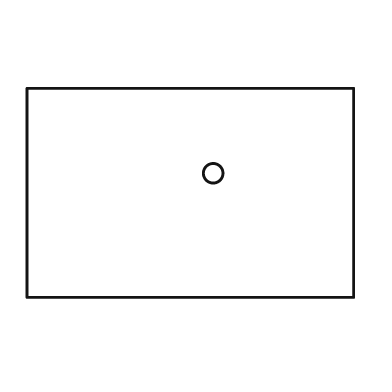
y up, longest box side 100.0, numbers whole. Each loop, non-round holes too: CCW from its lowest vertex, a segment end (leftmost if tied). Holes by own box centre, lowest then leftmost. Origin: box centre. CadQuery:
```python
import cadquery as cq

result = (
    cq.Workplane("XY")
    .moveTo(-50.0, -32.0)
    .lineTo(50.0, -32.0)
    .lineTo(50.0, 32.0)
    .lineTo(-50.0, 32.0)
    .close()
    .moveTo(7.0, 6.0)
    .circle(3.0)
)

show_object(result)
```